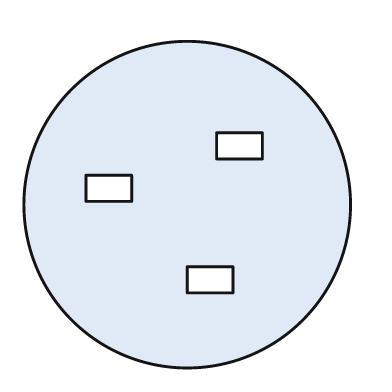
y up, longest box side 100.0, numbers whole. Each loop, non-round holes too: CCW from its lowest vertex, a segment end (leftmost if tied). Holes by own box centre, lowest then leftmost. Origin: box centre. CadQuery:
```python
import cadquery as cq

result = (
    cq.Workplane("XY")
    .moveTo(0.0, 0.0)
    .circle(50.0)
    .moveTo(0.0, -27.0)
    .lineTo(14.0, -27.0)
    .lineTo(14.0, -19.0)
    .lineTo(0.0, -19.0)
    .close()
    .moveTo(-31.0, 1.0)
    .lineTo(-17.0, 1.0)
    .lineTo(-17.0, 9.0)
    .lineTo(-31.0, 9.0)
    .close()
    .moveTo(9.0, 14.0)
    .lineTo(23.0, 14.0)
    .lineTo(23.0, 22.0)
    .lineTo(9.0, 22.0)
    .close()
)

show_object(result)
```